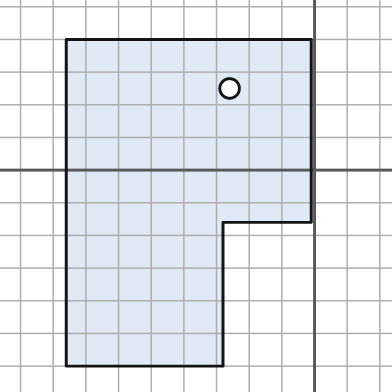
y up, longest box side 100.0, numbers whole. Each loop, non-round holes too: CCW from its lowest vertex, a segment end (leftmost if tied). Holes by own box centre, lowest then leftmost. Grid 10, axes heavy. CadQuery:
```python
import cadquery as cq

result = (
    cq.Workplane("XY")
    .moveTo(-76.0, -60.0)
    .lineTo(-28.0, -60.0)
    .lineTo(-28.0, -16.0)
    .lineTo(-1.0, -16.0)
    .lineTo(-1.0, 40.0)
    .lineTo(-76.0, 40.0)
    .close()
    .moveTo(-26.0, 25.0)
    .circle(3.0)
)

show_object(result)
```